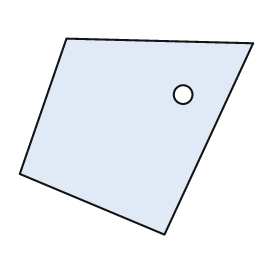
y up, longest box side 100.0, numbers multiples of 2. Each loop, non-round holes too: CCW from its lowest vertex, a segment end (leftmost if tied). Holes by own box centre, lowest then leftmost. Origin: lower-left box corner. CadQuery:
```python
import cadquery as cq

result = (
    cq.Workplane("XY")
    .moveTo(62.0, 0.0)
    .lineTo(100.0, 82.0)
    .lineTo(20.0, 84.0)
    .lineTo(0.0, 26.0)
    .close()
    .moveTo(70.0, 60.0)
    .circle(4.0)
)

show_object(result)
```